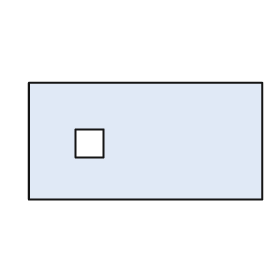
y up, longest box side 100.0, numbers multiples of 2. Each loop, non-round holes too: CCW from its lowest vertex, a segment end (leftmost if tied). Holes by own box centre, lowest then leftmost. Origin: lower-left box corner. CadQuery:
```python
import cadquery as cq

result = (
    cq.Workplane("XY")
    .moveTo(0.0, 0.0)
    .lineTo(100.0, 0.0)
    .lineTo(100.0, 50.0)
    .lineTo(0.0, 50.0)
    .close()
    .moveTo(20.0, 18.0)
    .lineTo(32.0, 18.0)
    .lineTo(32.0, 30.0)
    .lineTo(20.0, 30.0)
    .close()
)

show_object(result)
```